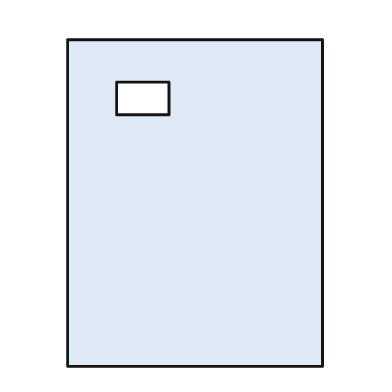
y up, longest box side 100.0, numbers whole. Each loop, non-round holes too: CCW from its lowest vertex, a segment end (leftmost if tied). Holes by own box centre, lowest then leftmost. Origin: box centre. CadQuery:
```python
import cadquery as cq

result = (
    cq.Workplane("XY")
    .moveTo(-39.0, -50.0)
    .lineTo(39.0, -50.0)
    .lineTo(39.0, 50.0)
    .lineTo(-39.0, 50.0)
    .close()
    .moveTo(-24.0, 27.0)
    .lineTo(-8.0, 27.0)
    .lineTo(-8.0, 37.0)
    .lineTo(-24.0, 37.0)
    .close()
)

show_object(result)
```